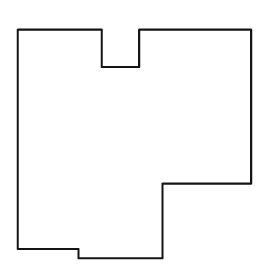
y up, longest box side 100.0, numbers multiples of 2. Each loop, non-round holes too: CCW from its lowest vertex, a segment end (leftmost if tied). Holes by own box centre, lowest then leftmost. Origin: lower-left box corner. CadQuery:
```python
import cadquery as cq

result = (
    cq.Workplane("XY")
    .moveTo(26.0, 0.0)
    .lineTo(62.0, 0.0)
    .lineTo(62.0, 32.0)
    .lineTo(100.0, 32.0)
    .lineTo(100.0, 98.0)
    .lineTo(52.0, 98.0)
    .lineTo(52.0, 82.0)
    .lineTo(36.0, 82.0)
    .lineTo(36.0, 98.0)
    .lineTo(0.0, 98.0)
    .lineTo(0.0, 4.0)
    .lineTo(26.0, 4.0)
    .close()
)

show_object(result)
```